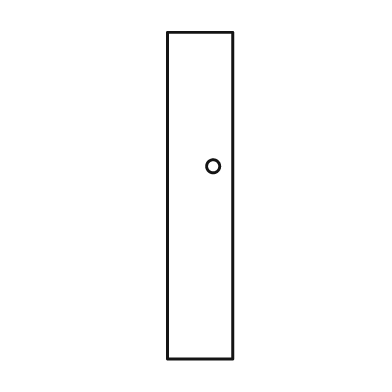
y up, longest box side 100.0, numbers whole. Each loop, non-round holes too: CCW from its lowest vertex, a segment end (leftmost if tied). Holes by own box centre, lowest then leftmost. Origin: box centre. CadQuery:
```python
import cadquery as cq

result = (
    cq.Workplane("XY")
    .moveTo(-10.0, -50.0)
    .lineTo(10.0, -50.0)
    .lineTo(10.0, 50.0)
    .lineTo(-10.0, 50.0)
    .close()
    .moveTo(4.0, 9.0)
    .circle(2.0)
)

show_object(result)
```